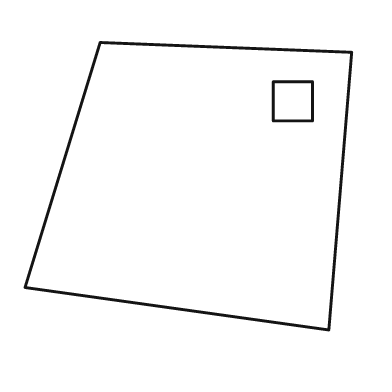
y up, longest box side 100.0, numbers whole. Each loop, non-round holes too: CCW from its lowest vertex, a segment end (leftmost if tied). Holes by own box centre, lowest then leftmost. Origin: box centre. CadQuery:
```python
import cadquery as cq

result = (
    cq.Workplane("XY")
    .moveTo(43.0, -44.0)
    .lineTo(50.0, 41.0)
    .lineTo(-27.0, 44.0)
    .lineTo(-50.0, -31.0)
    .close()
    .moveTo(26.0, 20.0)
    .lineTo(38.0, 20.0)
    .lineTo(38.0, 32.0)
    .lineTo(26.0, 32.0)
    .close()
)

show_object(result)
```